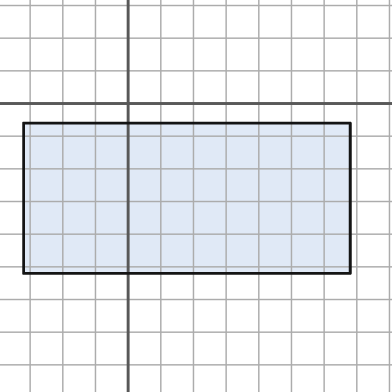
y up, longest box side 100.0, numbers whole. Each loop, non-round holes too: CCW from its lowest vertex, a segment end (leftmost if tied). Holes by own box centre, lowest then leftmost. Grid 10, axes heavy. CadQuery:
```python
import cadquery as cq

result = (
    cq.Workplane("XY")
    .moveTo(-32.0, -52.0)
    .lineTo(68.0, -52.0)
    .lineTo(68.0, -6.0)
    .lineTo(-32.0, -6.0)
    .close()
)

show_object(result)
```